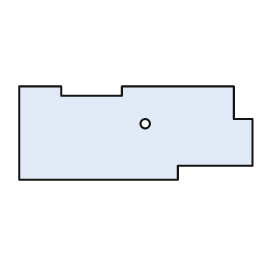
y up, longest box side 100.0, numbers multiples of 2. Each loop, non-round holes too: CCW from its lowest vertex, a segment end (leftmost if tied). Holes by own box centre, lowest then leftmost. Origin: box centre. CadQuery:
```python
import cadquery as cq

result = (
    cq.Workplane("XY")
    .moveTo(-50.0, -20.0)
    .lineTo(18.0, -20.0)
    .lineTo(18.0, -14.0)
    .lineTo(50.0, -14.0)
    .lineTo(50.0, 6.0)
    .lineTo(42.0, 6.0)
    .lineTo(42.0, 20.0)
    .lineTo(-6.0, 20.0)
    .lineTo(-6.0, 16.0)
    .lineTo(-32.0, 16.0)
    .lineTo(-32.0, 20.0)
    .lineTo(-50.0, 20.0)
    .close()
    .moveTo(4.0, 4.0)
    .circle(2.0)
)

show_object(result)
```